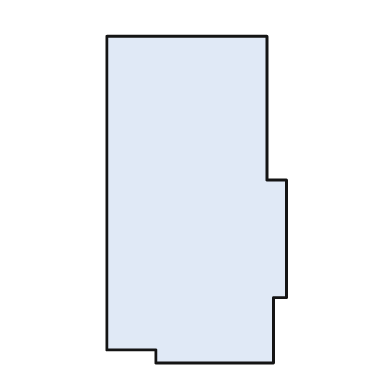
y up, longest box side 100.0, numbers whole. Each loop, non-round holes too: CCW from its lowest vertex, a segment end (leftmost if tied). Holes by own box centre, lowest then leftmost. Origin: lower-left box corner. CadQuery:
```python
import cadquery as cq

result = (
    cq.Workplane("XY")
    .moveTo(15.0, 0.0)
    .lineTo(51.0, 0.0)
    .lineTo(51.0, 20.0)
    .lineTo(55.0, 20.0)
    .lineTo(55.0, 56.0)
    .lineTo(49.0, 56.0)
    .lineTo(49.0, 100.0)
    .lineTo(0.0, 100.0)
    .lineTo(0.0, 4.0)
    .lineTo(15.0, 4.0)
    .close()
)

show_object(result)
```